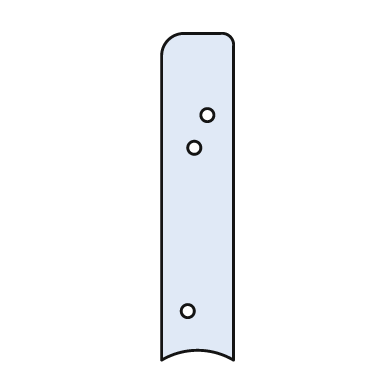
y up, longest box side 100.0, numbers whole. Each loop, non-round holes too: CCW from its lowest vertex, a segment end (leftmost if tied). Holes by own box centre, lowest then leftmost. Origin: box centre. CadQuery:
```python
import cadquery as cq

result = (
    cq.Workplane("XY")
    .moveTo(-11.0, -50.0)
    .threePointArc((0.0, -47.0), (11.0, -50.0))
    .lineTo(11.0, 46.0)
    .threePointArc((10.0, 49.0), (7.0, 50.0))
    .lineTo(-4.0, 50.0)
    .threePointArc((-9.0, 48.0), (-11.0, 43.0))
    .close()
    .moveTo(-3.0, -35.0)
    .circle(2.0)
    .moveTo(-1.0, 15.0)
    .circle(2.0)
    .moveTo(3.0, 25.0)
    .circle(2.0)
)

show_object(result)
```